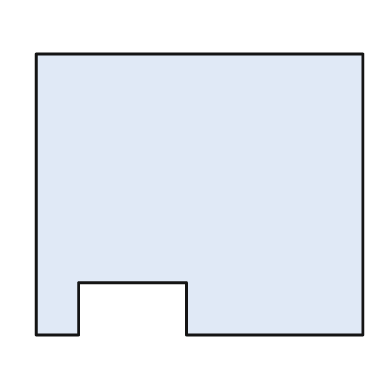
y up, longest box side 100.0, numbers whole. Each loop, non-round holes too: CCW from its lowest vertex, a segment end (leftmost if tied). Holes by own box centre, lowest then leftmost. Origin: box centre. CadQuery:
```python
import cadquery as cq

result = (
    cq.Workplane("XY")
    .moveTo(-50.0, -43.0)
    .lineTo(-37.0, -43.0)
    .lineTo(-37.0, -27.0)
    .lineTo(-4.0, -27.0)
    .lineTo(-4.0, -43.0)
    .lineTo(50.0, -43.0)
    .lineTo(50.0, 43.0)
    .lineTo(-50.0, 43.0)
    .close()
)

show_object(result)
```